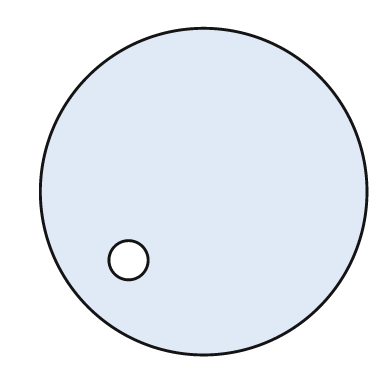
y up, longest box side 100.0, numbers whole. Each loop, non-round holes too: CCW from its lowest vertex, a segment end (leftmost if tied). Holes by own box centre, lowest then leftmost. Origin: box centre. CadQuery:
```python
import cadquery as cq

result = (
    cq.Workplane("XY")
    .moveTo(0.0, 0.0)
    .circle(50.0)
    .moveTo(-23.0, -21.0)
    .circle(6.0)
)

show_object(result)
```